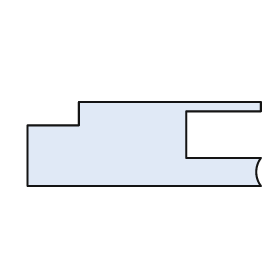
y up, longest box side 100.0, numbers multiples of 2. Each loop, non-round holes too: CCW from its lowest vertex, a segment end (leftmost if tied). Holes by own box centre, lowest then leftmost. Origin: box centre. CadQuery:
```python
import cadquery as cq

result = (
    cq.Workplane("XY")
    .moveTo(-50.0, -18.0)
    .lineTo(50.0, -18.0)
    .threePointArc((48.0, -12.0), (50.0, -6.0))
    .lineTo(18.0, -6.0)
    .lineTo(18.0, 14.0)
    .lineTo(50.0, 14.0)
    .lineTo(50.0, 18.0)
    .lineTo(-28.0, 18.0)
    .lineTo(-28.0, 8.0)
    .lineTo(-50.0, 8.0)
    .close()
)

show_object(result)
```